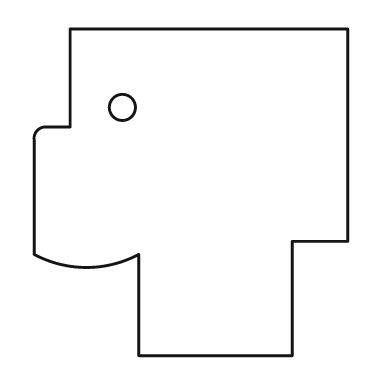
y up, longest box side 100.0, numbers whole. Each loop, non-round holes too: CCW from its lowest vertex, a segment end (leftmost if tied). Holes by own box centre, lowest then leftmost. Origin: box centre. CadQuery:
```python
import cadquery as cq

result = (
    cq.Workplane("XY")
    .moveTo(-16.0, -50.0)
    .lineTo(31.0, -50.0)
    .lineTo(31.0, -15.0)
    .lineTo(48.0, -15.0)
    .lineTo(48.0, 50.0)
    .lineTo(-37.0, 50.0)
    .lineTo(-37.0, 20.0)
    .lineTo(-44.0, 20.0)
    .threePointArc((-47.0, 19.0), (-48.0, 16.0))
    .lineTo(-48.0, -19.0)
    .threePointArc((-32.0, -23.0), (-16.0, -19.0))
    .close()
    .moveTo(-21.0, 26.0)
    .circle(4.0)
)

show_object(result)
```